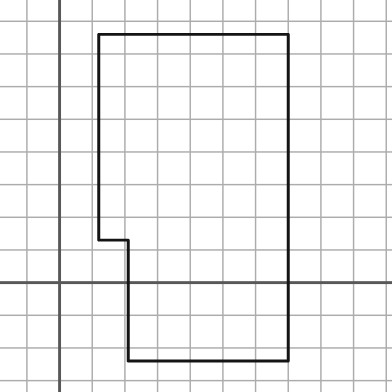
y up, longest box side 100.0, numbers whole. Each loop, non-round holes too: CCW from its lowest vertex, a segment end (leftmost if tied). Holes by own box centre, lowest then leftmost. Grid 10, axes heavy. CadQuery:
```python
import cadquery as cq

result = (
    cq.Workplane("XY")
    .moveTo(21.0, -24.0)
    .lineTo(70.0, -24.0)
    .lineTo(70.0, 76.0)
    .lineTo(12.0, 76.0)
    .lineTo(12.0, 13.0)
    .lineTo(21.0, 13.0)
    .close()
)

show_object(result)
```